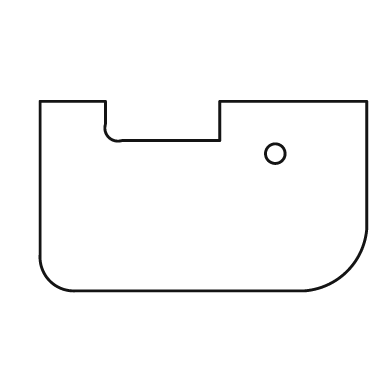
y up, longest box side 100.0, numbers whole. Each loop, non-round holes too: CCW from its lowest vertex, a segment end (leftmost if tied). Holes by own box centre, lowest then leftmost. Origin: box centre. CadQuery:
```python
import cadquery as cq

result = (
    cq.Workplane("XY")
    .moveTo(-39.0, -29.0)
    .lineTo(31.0, -29.0)
    .threePointArc((44.0, -23.0), (50.0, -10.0))
    .lineTo(50.0, 29.0)
    .lineTo(5.0, 29.0)
    .lineTo(5.0, 17.0)
    .lineTo(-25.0, 17.0)
    .threePointArc((-29.0, 18.0), (-30.0, 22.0))
    .lineTo(-30.0, 29.0)
    .lineTo(-50.0, 29.0)
    .lineTo(-50.0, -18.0)
    .threePointArc((-47.0, -26.0), (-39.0, -29.0))
    .close()
    .moveTo(22.0, 13.0)
    .circle(3.0)
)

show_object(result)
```